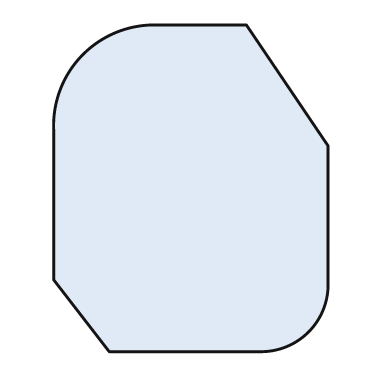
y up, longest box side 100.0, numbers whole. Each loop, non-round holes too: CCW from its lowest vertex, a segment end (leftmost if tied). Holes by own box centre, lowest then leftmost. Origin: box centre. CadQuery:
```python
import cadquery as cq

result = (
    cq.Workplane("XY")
    .moveTo(-25.0, -50.0)
    .lineTo(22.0, -50.0)
    .threePointArc((36.0, -44.0), (42.0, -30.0))
    .lineTo(42.0, 13.0)
    .lineTo(17.0, 50.0)
    .lineTo(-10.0, 50.0)
    .threePointArc((-33.0, 41.0), (-42.0, 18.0))
    .lineTo(-42.0, -28.0)
    .close()
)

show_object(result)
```